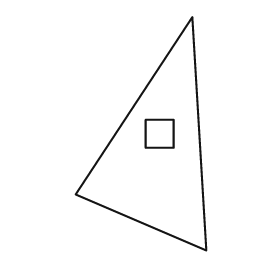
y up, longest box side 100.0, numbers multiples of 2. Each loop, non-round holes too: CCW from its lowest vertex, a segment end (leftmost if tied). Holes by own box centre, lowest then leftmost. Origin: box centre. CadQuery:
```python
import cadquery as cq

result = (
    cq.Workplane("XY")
    .moveTo(28.0, -50.0)
    .lineTo(22.0, 50.0)
    .lineTo(-28.0, -26.0)
    .close()
    .moveTo(2.0, -6.0)
    .lineTo(14.0, -6.0)
    .lineTo(14.0, 6.0)
    .lineTo(2.0, 6.0)
    .close()
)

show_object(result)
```